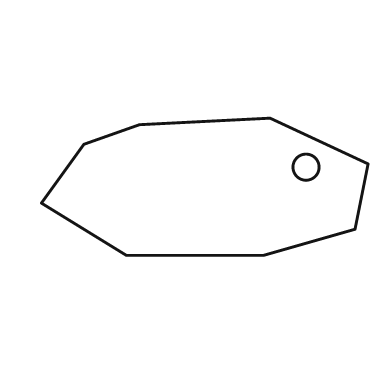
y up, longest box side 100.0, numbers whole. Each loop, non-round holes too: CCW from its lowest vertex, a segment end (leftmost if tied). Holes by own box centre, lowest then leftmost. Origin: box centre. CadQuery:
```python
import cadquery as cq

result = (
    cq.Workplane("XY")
    .moveTo(-24.0, -21.0)
    .lineTo(18.0, -21.0)
    .lineTo(46.0, -13.0)
    .lineTo(50.0, 7.0)
    .lineTo(20.0, 21.0)
    .lineTo(-20.0, 19.0)
    .lineTo(-37.0, 13.0)
    .lineTo(-50.0, -5.0)
    .close()
    .moveTo(31.0, 6.0)
    .circle(4.0)
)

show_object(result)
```